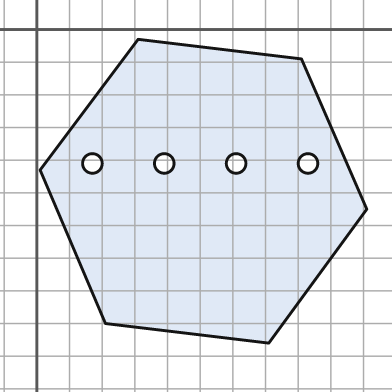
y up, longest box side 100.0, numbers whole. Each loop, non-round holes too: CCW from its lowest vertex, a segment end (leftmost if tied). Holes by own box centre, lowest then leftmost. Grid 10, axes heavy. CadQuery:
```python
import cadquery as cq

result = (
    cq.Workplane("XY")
    .moveTo(71.0, -96.0)
    .lineTo(101.0, -55.0)
    .lineTo(81.0, -9.0)
    .lineTo(31.0, -3.0)
    .lineTo(1.0, -43.0)
    .lineTo(21.0, -90.0)
    .close()
    .moveTo(17.0, -41.0)
    .circle(3.0)
    .moveTo(39.0, -41.0)
    .circle(3.0)
    .moveTo(61.0, -41.0)
    .circle(3.0)
    .moveTo(83.0, -41.0)
    .circle(3.0)
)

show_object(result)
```